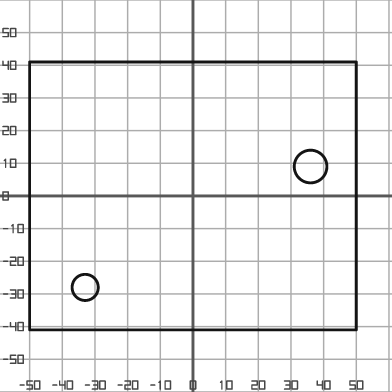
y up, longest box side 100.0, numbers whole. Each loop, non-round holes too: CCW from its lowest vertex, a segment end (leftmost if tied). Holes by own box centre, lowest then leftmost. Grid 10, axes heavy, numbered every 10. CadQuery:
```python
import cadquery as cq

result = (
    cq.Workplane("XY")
    .moveTo(-50.0, -41.0)
    .lineTo(50.0, -41.0)
    .lineTo(50.0, 41.0)
    .lineTo(-50.0, 41.0)
    .close()
    .moveTo(-33.0, -28.0)
    .circle(4.0)
    .moveTo(36.0, 9.0)
    .circle(5.0)
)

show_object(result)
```